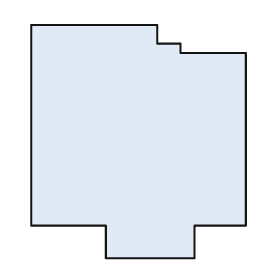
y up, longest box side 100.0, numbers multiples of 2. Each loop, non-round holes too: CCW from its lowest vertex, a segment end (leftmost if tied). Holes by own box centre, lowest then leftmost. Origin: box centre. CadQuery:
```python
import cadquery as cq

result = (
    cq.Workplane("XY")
    .moveTo(-14.0, -50.0)
    .lineTo(24.0, -50.0)
    .lineTo(24.0, -36.0)
    .lineTo(46.0, -36.0)
    .lineTo(46.0, 38.0)
    .lineTo(18.0, 38.0)
    .lineTo(18.0, 42.0)
    .lineTo(8.0, 42.0)
    .lineTo(8.0, 50.0)
    .lineTo(-46.0, 50.0)
    .lineTo(-46.0, -36.0)
    .lineTo(-14.0, -36.0)
    .close()
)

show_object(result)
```